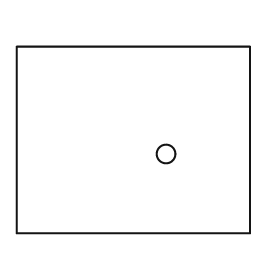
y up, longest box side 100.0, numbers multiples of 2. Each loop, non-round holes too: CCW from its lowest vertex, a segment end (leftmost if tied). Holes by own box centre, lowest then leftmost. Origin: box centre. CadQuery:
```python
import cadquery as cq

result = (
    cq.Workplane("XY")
    .moveTo(-50.0, -40.0)
    .lineTo(50.0, -40.0)
    .lineTo(50.0, 40.0)
    .lineTo(-50.0, 40.0)
    .close()
    .moveTo(14.0, -6.0)
    .circle(4.0)
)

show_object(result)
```